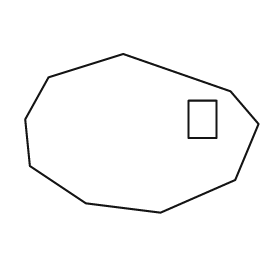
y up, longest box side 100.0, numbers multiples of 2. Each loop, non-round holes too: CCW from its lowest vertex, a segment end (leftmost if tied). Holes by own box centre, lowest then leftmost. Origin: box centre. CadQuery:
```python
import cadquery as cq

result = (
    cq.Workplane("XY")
    .moveTo(8.0, -34.0)
    .lineTo(40.0, -20.0)
    .lineTo(50.0, 4.0)
    .lineTo(38.0, 18.0)
    .lineTo(-8.0, 34.0)
    .lineTo(-40.0, 24.0)
    .lineTo(-50.0, 6.0)
    .lineTo(-48.0, -14.0)
    .lineTo(-24.0, -30.0)
    .close()
    .moveTo(20.0, -2.0)
    .lineTo(32.0, -2.0)
    .lineTo(32.0, 14.0)
    .lineTo(20.0, 14.0)
    .close()
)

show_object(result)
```